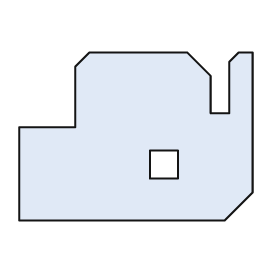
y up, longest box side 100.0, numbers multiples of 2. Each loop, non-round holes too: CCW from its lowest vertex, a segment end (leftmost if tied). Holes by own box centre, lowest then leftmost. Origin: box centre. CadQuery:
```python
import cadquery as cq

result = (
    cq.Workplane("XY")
    .moveTo(-50.0, -36.0)
    .lineTo(38.0, -36.0)
    .lineTo(50.0, -24.0)
    .lineTo(50.0, 36.0)
    .lineTo(44.0, 36.0)
    .lineTo(40.0, 32.0)
    .lineTo(40.0, 10.0)
    .lineTo(32.0, 10.0)
    .lineTo(32.0, 26.0)
    .lineTo(22.0, 36.0)
    .lineTo(-20.0, 36.0)
    .lineTo(-26.0, 30.0)
    .lineTo(-26.0, 4.0)
    .lineTo(-50.0, 4.0)
    .close()
    .moveTo(6.0, -18.0)
    .lineTo(18.0, -18.0)
    .lineTo(18.0, -6.0)
    .lineTo(6.0, -6.0)
    .close()
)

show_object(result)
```